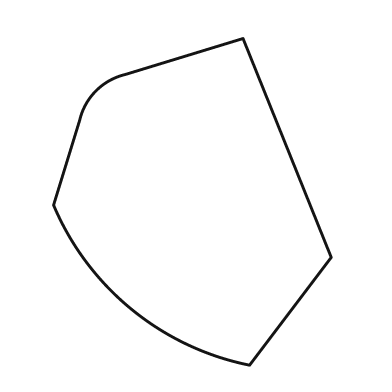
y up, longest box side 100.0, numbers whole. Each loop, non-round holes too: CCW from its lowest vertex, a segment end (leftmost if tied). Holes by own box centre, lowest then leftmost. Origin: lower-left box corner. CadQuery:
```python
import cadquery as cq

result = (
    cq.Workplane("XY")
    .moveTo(60.0, 0.0)
    .lineTo(85.0, 33.0)
    .lineTo(58.0, 100.0)
    .lineTo(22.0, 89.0)
    .threePointArc((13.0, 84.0), (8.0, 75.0))
    .lineTo(0.0, 49.0)
    .threePointArc((24.0, 17.0), (60.0, 0.0))
    .close()
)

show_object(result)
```